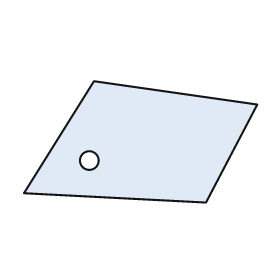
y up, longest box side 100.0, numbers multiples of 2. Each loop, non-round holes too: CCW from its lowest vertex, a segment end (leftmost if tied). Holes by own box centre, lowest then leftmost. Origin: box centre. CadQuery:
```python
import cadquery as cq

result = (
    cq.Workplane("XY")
    .moveTo(28.0, -26.0)
    .lineTo(50.0, 16.0)
    .lineTo(-20.0, 26.0)
    .lineTo(-50.0, -22.0)
    .close()
    .moveTo(-22.0, -8.0)
    .circle(4.0)
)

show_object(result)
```